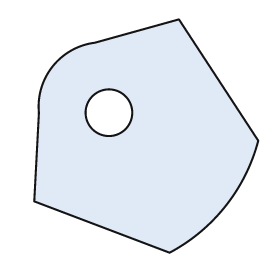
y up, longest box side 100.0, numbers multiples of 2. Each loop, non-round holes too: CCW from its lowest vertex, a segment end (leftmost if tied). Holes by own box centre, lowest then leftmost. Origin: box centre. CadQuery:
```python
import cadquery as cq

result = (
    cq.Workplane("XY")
    .moveTo(10.0, -50.0)
    .threePointArc((34.0, -30.0), (48.0, -2.0))
    .lineTo(14.0, 50.0)
    .lineTo(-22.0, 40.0)
    .threePointArc((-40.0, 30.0), (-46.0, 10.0))
    .lineTo(-48.0, -28.0)
    .close()
    .moveTo(-16.0, 10.0)
    .circle(10.0)
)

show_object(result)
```